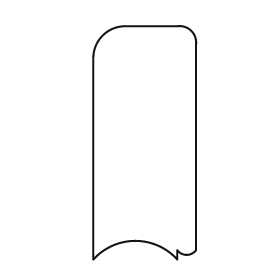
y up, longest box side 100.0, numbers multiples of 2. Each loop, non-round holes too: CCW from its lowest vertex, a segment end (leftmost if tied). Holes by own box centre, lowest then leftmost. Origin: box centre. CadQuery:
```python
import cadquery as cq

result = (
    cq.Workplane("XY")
    .moveTo(-22.0, -50.0)
    .threePointArc((-4.0, -42.0), (14.0, -50.0))
    .lineTo(14.0, -46.0)
    .threePointArc((18.0, -48.0), (22.0, -46.0))
    .lineTo(22.0, 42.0)
    .threePointArc((20.0, 48.0), (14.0, 50.0))
    .lineTo(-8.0, 50.0)
    .threePointArc((-18.0, 46.0), (-22.0, 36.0))
    .close()
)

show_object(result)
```